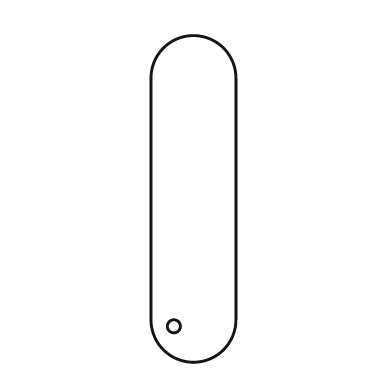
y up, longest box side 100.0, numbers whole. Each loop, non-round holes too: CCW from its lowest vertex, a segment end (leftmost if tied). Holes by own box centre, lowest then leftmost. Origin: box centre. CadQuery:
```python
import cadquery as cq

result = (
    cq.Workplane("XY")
    .moveTo(-13.0, -37.0)
    .threePointArc((0.0, -50.0), (13.0, -37.0))
    .lineTo(13.0, 37.0)
    .threePointArc((0.0, 50.0), (-13.0, 37.0))
    .close()
    .moveTo(-6.0, -39.0)
    .circle(2.0)
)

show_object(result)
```